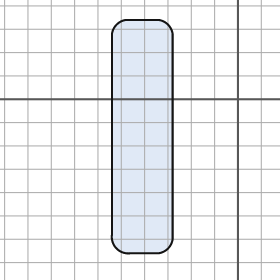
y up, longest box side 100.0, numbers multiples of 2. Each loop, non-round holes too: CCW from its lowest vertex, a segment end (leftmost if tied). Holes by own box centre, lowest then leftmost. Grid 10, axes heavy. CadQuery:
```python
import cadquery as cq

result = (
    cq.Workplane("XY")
    .moveTo(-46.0, -66.0)
    .lineTo(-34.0, -66.0)
    .threePointArc((-30.0, -64.0), (-28.0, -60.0))
    .lineTo(-28.0, 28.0)
    .threePointArc((-30.0, 32.0), (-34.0, 34.0))
    .lineTo(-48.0, 34.0)
    .threePointArc((-52.0, 32.0), (-54.0, 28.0))
    .lineTo(-54.0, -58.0)
    .threePointArc((-52.0, -64.0), (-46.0, -66.0))
    .close()
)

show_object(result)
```